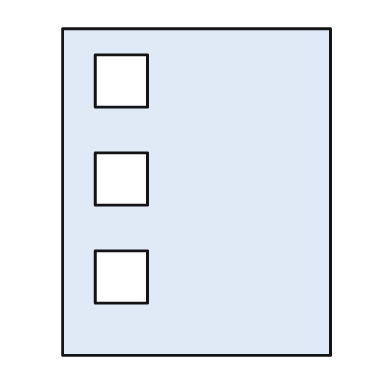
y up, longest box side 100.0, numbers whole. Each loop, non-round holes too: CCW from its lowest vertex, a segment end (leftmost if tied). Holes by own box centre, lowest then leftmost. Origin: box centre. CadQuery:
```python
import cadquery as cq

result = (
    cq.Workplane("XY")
    .moveTo(-41.0, -50.0)
    .lineTo(41.0, -50.0)
    .lineTo(41.0, 50.0)
    .lineTo(-41.0, 50.0)
    .close()
    .moveTo(-31.0, -34.0)
    .lineTo(-15.0, -34.0)
    .lineTo(-15.0, -18.0)
    .lineTo(-31.0, -18.0)
    .close()
    .moveTo(-31.0, -4.0)
    .lineTo(-15.0, -4.0)
    .lineTo(-15.0, 12.0)
    .lineTo(-31.0, 12.0)
    .close()
    .moveTo(-31.0, 26.0)
    .lineTo(-15.0, 26.0)
    .lineTo(-15.0, 42.0)
    .lineTo(-31.0, 42.0)
    .close()
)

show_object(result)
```